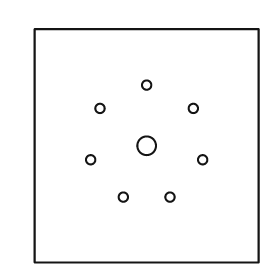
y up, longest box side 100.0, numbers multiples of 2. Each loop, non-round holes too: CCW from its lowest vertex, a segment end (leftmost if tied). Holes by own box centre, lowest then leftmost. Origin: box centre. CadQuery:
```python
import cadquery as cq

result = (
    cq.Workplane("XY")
    .moveTo(-48.0, -50.0)
    .lineTo(48.0, -50.0)
    .lineTo(48.0, 50.0)
    .lineTo(-48.0, 50.0)
    .close()
    .moveTo(-10.0, -22.0)
    .circle(2.0)
    .moveTo(10.0, -22.0)
    .circle(2.0)
    .moveTo(-24.0, -6.0)
    .circle(2.0)
    .moveTo(24.0, -6.0)
    .circle(2.0)
    .moveTo(0.0, 0.0)
    .circle(4.0)
    .moveTo(-20.0, 16.0)
    .circle(2.0)
    .moveTo(20.0, 16.0)
    .circle(2.0)
    .moveTo(0.0, 26.0)
    .circle(2.0)
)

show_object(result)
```